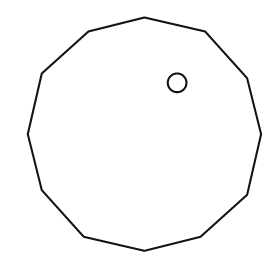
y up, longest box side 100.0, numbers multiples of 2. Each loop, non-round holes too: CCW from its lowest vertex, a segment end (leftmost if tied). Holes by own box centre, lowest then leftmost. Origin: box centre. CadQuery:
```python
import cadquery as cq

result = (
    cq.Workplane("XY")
    .moveTo(0.0, -50.0)
    .lineTo(24.0, -44.0)
    .lineTo(44.0, -26.0)
    .lineTo(50.0, 0.0)
    .lineTo(44.0, 24.0)
    .lineTo(26.0, 44.0)
    .lineTo(0.0, 50.0)
    .lineTo(-24.0, 44.0)
    .lineTo(-44.0, 26.0)
    .lineTo(-50.0, 0.0)
    .lineTo(-44.0, -24.0)
    .lineTo(-26.0, -44.0)
    .close()
    .moveTo(14.0, 22.0)
    .circle(4.0)
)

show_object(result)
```